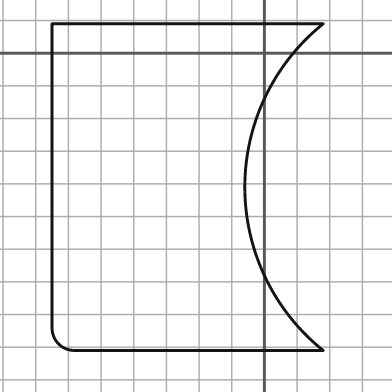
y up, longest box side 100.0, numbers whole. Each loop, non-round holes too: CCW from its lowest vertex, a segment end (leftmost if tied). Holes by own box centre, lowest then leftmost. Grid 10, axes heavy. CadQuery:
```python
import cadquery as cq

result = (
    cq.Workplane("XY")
    .moveTo(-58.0, -91.0)
    .lineTo(18.0, -91.0)
    .threePointArc((-6.0, -41.0), (18.0, 9.0))
    .lineTo(-65.0, 9.0)
    .lineTo(-65.0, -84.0)
    .threePointArc((-63.0, -89.0), (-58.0, -91.0))
    .close()
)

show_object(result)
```